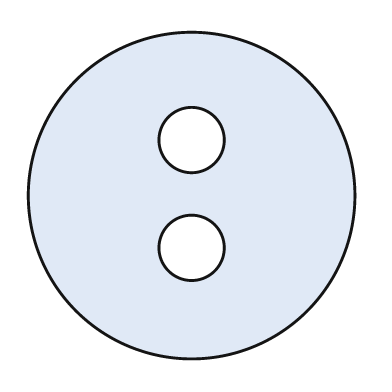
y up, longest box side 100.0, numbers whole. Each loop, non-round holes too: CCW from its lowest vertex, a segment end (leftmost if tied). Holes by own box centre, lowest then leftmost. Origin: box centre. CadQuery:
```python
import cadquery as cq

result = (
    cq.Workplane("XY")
    .moveTo(0.0, 0.0)
    .circle(50.0)
    .moveTo(0.0, -16.0)
    .circle(10.0)
    .moveTo(0.0, 17.0)
    .circle(10.0)
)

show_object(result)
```